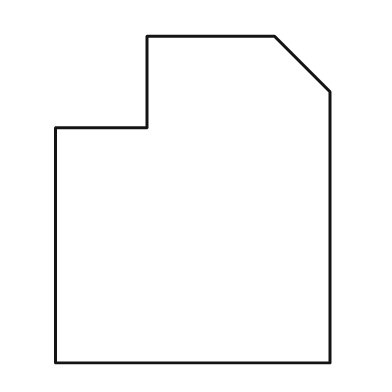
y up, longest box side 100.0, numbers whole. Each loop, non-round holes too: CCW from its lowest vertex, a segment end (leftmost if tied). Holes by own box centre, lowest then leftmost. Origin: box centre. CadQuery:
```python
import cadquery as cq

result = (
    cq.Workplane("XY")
    .moveTo(-42.0, -50.0)
    .lineTo(42.0, -50.0)
    .lineTo(42.0, 33.0)
    .lineTo(25.0, 50.0)
    .lineTo(-14.0, 50.0)
    .lineTo(-14.0, 22.0)
    .lineTo(-42.0, 22.0)
    .close()
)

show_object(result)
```